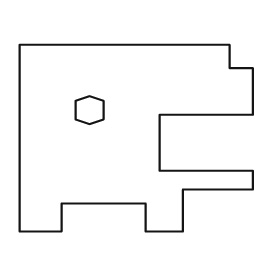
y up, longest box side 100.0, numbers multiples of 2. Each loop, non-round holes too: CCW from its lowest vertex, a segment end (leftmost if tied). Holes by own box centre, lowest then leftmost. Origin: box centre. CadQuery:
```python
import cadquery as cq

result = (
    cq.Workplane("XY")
    .moveTo(-50.0, -40.0)
    .lineTo(-32.0, -40.0)
    .lineTo(-32.0, -28.0)
    .lineTo(4.0, -28.0)
    .lineTo(4.0, -40.0)
    .lineTo(20.0, -40.0)
    .lineTo(20.0, -22.0)
    .lineTo(50.0, -22.0)
    .lineTo(50.0, -14.0)
    .lineTo(10.0, -14.0)
    .lineTo(10.0, 10.0)
    .lineTo(50.0, 10.0)
    .lineTo(50.0, 30.0)
    .lineTo(40.0, 30.0)
    .lineTo(40.0, 40.0)
    .lineTo(-50.0, 40.0)
    .close()
    .moveTo(-20.0, 6.0)
    .lineTo(-14.0, 8.0)
    .lineTo(-14.0, 16.0)
    .lineTo(-20.0, 18.0)
    .lineTo(-26.0, 16.0)
    .lineTo(-26.0, 8.0)
    .close()
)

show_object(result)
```